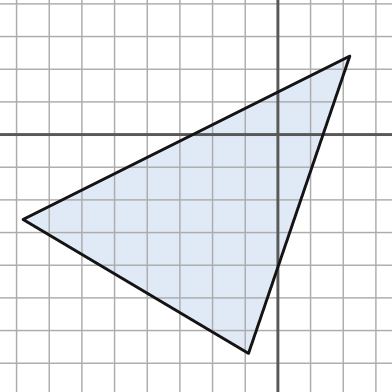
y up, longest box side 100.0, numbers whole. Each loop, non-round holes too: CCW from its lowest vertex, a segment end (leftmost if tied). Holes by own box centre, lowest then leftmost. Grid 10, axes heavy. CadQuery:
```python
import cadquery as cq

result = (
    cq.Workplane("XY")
    .moveTo(-9.0, -67.0)
    .lineTo(22.0, 24.0)
    .lineTo(-78.0, -26.0)
    .close()
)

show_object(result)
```